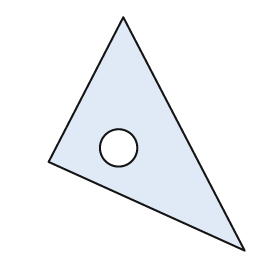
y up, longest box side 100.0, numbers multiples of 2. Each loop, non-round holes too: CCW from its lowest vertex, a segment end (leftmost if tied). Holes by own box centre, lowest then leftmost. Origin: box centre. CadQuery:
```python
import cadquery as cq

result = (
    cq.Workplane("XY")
    .moveTo(42.0, -50.0)
    .lineTo(-10.0, 50.0)
    .lineTo(-42.0, -12.0)
    .close()
    .moveTo(-12.0, -6.0)
    .circle(8.0)
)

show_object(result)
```